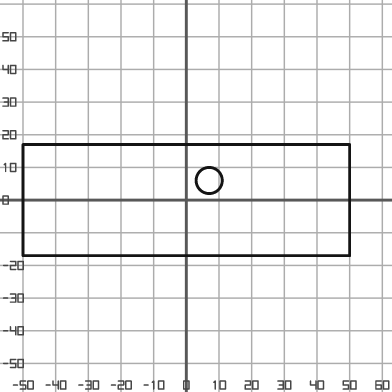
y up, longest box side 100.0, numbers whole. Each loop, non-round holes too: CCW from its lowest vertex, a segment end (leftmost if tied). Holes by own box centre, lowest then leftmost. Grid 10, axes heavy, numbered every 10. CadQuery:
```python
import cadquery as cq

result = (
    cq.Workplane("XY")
    .moveTo(-50.0, -17.0)
    .lineTo(50.0, -17.0)
    .lineTo(50.0, 17.0)
    .lineTo(-50.0, 17.0)
    .close()
    .moveTo(7.0, 6.0)
    .circle(4.0)
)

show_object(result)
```